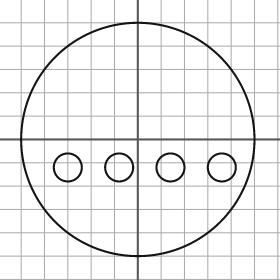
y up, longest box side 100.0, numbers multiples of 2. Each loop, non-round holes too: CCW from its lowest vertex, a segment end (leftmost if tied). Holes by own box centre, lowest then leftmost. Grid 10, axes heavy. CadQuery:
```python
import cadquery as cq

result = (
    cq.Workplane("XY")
    .moveTo(0.0, 0.0)
    .circle(50.0)
    .moveTo(-30.0, -12.0)
    .circle(6.0)
    .moveTo(-8.0, -12.0)
    .circle(6.0)
    .moveTo(14.0, -12.0)
    .circle(6.0)
    .moveTo(36.0, -12.0)
    .circle(6.0)
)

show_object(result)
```